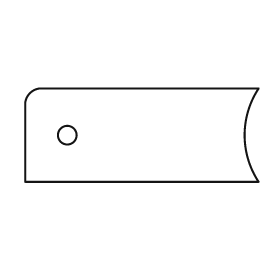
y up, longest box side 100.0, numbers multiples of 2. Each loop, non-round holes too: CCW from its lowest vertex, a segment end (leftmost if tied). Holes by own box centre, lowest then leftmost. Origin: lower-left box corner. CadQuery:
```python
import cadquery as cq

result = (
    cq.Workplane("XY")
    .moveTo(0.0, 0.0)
    .lineTo(100.0, 0.0)
    .threePointArc((94.0, 20.0), (100.0, 40.0))
    .lineTo(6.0, 40.0)
    .threePointArc((2.0, 38.0), (0.0, 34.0))
    .close()
    .moveTo(18.0, 20.0)
    .circle(4.0)
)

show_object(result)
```